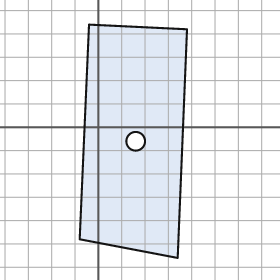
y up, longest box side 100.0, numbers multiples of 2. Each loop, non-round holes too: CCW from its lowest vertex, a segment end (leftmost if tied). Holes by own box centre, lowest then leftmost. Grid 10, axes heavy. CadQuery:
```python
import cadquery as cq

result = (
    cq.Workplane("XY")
    .moveTo(34.0, -56.0)
    .lineTo(38.0, 42.0)
    .lineTo(-4.0, 44.0)
    .lineTo(-8.0, -48.0)
    .close()
    .moveTo(16.0, -6.0)
    .circle(4.0)
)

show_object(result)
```